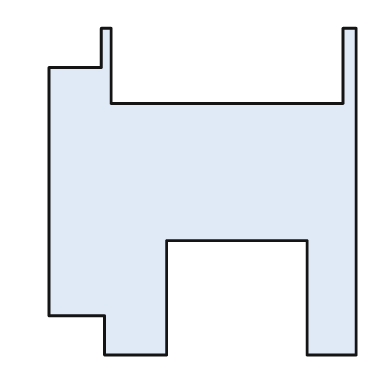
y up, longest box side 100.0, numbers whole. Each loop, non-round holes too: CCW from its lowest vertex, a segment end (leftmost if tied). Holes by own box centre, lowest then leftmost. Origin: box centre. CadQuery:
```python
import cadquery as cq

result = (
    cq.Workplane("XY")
    .moveTo(-30.0, -50.0)
    .lineTo(-11.0, -50.0)
    .lineTo(-11.0, -15.0)
    .lineTo(32.0, -15.0)
    .lineTo(32.0, -50.0)
    .lineTo(47.0, -50.0)
    .lineTo(47.0, 50.0)
    .lineTo(43.0, 50.0)
    .lineTo(43.0, 27.0)
    .lineTo(-28.0, 27.0)
    .lineTo(-28.0, 50.0)
    .lineTo(-31.0, 50.0)
    .lineTo(-31.0, 38.0)
    .lineTo(-47.0, 38.0)
    .lineTo(-47.0, -38.0)
    .lineTo(-30.0, -38.0)
    .close()
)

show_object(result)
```